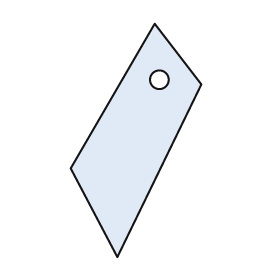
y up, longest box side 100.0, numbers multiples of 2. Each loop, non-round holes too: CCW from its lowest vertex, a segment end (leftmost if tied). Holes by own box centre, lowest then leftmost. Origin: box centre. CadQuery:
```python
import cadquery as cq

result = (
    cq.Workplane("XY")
    .moveTo(-8.0, -50.0)
    .lineTo(28.0, 24.0)
    .lineTo(8.0, 50.0)
    .lineTo(-28.0, -12.0)
    .close()
    .moveTo(10.0, 26.0)
    .circle(4.0)
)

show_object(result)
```